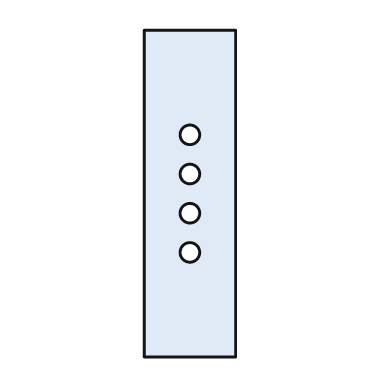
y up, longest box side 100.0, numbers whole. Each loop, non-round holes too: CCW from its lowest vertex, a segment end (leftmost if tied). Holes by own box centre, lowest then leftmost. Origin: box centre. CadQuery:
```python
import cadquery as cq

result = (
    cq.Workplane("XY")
    .moveTo(-14.0, -50.0)
    .lineTo(14.0, -50.0)
    .lineTo(14.0, 50.0)
    .lineTo(-14.0, 50.0)
    .close()
    .moveTo(0.0, -18.0)
    .circle(3.0)
    .moveTo(0.0, -6.0)
    .circle(3.0)
    .moveTo(0.0, 6.0)
    .circle(3.0)
    .moveTo(0.0, 18.0)
    .circle(3.0)
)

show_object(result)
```